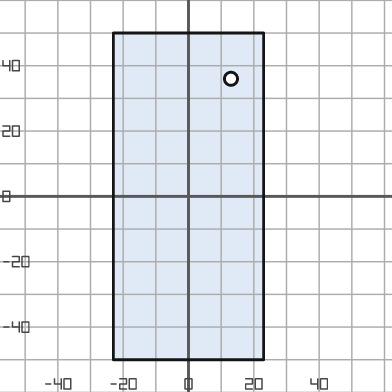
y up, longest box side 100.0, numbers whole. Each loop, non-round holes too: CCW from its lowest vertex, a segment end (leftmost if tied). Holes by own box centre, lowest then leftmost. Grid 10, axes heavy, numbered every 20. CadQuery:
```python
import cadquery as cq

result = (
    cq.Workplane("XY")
    .moveTo(-23.0, -50.0)
    .lineTo(23.0, -50.0)
    .lineTo(23.0, 50.0)
    .lineTo(-23.0, 50.0)
    .close()
    .moveTo(13.0, 36.0)
    .circle(2.0)
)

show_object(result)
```